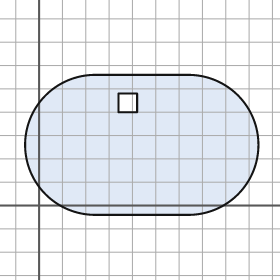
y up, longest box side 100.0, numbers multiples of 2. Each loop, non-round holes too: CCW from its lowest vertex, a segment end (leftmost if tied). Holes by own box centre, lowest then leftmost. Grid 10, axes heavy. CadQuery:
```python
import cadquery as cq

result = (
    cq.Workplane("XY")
    .moveTo(24.0, -4.0)
    .lineTo(64.0, -4.0)
    .threePointArc((94.0, 26.0), (64.0, 56.0))
    .lineTo(24.0, 56.0)
    .threePointArc((-6.0, 26.0), (24.0, -4.0))
    .close()
    .moveTo(34.0, 40.0)
    .lineTo(42.0, 40.0)
    .lineTo(42.0, 48.0)
    .lineTo(34.0, 48.0)
    .close()
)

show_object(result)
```